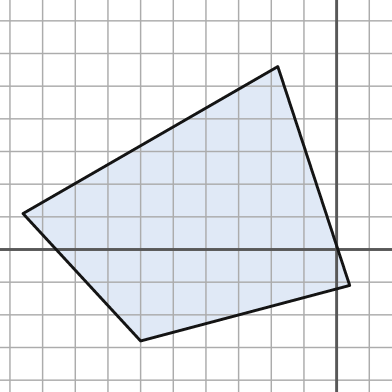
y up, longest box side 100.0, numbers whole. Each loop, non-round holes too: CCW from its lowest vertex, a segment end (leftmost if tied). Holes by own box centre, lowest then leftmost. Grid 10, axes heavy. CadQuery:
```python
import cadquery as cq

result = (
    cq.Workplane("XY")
    .moveTo(-60.0, -28.0)
    .lineTo(4.0, -11.0)
    .lineTo(-18.0, 56.0)
    .lineTo(-96.0, 11.0)
    .close()
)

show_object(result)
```